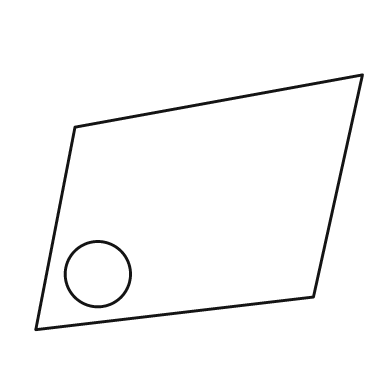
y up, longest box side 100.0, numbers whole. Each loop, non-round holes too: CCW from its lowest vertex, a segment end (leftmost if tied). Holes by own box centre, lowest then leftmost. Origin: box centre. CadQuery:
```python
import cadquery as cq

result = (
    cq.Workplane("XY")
    .moveTo(-50.0, -39.0)
    .lineTo(35.0, -29.0)
    .lineTo(50.0, 39.0)
    .lineTo(-38.0, 23.0)
    .close()
    .moveTo(-31.0, -22.0)
    .circle(10.0)
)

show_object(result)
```